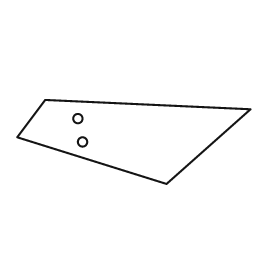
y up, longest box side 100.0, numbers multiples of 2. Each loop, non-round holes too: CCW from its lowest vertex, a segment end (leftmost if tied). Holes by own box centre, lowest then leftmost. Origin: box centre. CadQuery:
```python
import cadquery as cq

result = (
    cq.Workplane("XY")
    .moveTo(14.0, -18.0)
    .lineTo(50.0, 14.0)
    .lineTo(-38.0, 18.0)
    .lineTo(-50.0, 2.0)
    .close()
    .moveTo(-22.0, 0.0)
    .circle(2.0)
    .moveTo(-24.0, 10.0)
    .circle(2.0)
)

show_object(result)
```